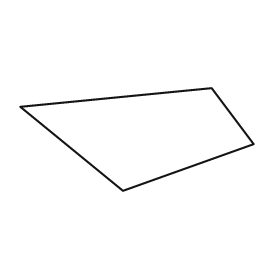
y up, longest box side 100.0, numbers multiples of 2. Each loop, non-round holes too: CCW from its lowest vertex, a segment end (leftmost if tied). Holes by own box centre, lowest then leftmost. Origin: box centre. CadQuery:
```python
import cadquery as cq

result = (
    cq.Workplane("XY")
    .moveTo(-6.0, -22.0)
    .lineTo(50.0, -2.0)
    .lineTo(32.0, 22.0)
    .lineTo(-50.0, 14.0)
    .close()
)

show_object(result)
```